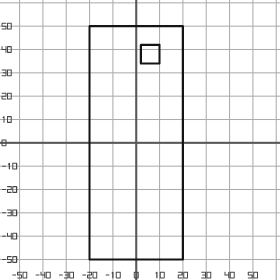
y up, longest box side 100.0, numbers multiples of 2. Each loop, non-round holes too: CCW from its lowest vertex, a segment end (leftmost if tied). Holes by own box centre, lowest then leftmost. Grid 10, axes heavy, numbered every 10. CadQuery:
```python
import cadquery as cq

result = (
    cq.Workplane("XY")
    .moveTo(-20.0, -50.0)
    .lineTo(20.0, -50.0)
    .lineTo(20.0, 50.0)
    .lineTo(-20.0, 50.0)
    .close()
    .moveTo(2.0, 34.0)
    .lineTo(10.0, 34.0)
    .lineTo(10.0, 42.0)
    .lineTo(2.0, 42.0)
    .close()
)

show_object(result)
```